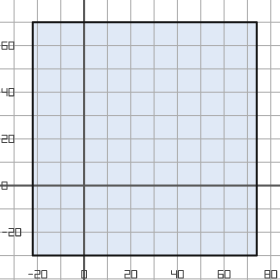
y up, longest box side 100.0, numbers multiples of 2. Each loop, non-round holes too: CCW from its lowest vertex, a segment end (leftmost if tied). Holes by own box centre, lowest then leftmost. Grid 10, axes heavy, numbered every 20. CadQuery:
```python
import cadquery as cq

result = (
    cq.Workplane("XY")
    .moveTo(-22.0, -30.0)
    .lineTo(74.0, -30.0)
    .lineTo(74.0, 70.0)
    .lineTo(-22.0, 70.0)
    .close()
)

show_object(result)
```